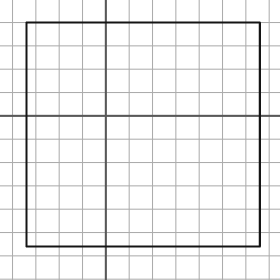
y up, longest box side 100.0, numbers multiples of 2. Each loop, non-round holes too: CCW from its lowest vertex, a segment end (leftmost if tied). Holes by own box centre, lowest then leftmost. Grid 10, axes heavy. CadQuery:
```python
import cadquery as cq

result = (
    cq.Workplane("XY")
    .moveTo(-34.0, -56.0)
    .lineTo(66.0, -56.0)
    .lineTo(66.0, 40.0)
    .lineTo(-34.0, 40.0)
    .close()
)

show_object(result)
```